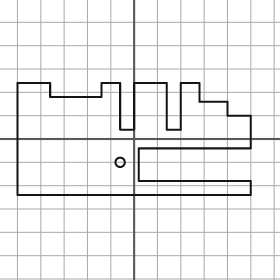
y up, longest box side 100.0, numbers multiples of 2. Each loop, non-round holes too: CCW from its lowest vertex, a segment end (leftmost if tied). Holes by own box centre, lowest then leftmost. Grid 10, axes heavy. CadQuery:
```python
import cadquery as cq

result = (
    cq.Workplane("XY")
    .moveTo(-50.0, -24.0)
    .lineTo(50.0, -24.0)
    .lineTo(50.0, -18.0)
    .lineTo(2.0, -18.0)
    .lineTo(2.0, -4.0)
    .lineTo(50.0, -4.0)
    .lineTo(50.0, 10.0)
    .lineTo(40.0, 10.0)
    .lineTo(40.0, 16.0)
    .lineTo(28.0, 16.0)
    .lineTo(28.0, 24.0)
    .lineTo(20.0, 24.0)
    .lineTo(20.0, 4.0)
    .lineTo(14.0, 4.0)
    .lineTo(14.0, 24.0)
    .lineTo(0.0, 24.0)
    .lineTo(0.0, 4.0)
    .lineTo(-6.0, 4.0)
    .lineTo(-6.0, 24.0)
    .lineTo(-14.0, 24.0)
    .lineTo(-14.0, 18.0)
    .lineTo(-36.0, 18.0)
    .lineTo(-36.0, 24.0)
    .lineTo(-50.0, 24.0)
    .close()
    .moveTo(-6.0, -10.0)
    .circle(2.0)
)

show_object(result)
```